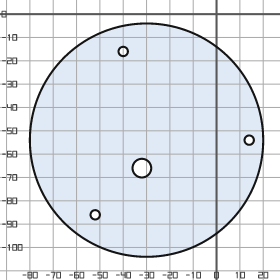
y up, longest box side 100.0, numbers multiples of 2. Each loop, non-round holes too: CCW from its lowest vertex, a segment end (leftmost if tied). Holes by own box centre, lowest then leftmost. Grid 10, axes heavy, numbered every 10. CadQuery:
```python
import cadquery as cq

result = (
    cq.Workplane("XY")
    .moveTo(-30.0, -54.0)
    .circle(50.0)
    .moveTo(-52.0, -86.0)
    .circle(2.0)
    .moveTo(-32.0, -66.0)
    .circle(4.0)
    .moveTo(14.0, -54.0)
    .circle(2.0)
    .moveTo(-40.0, -16.0)
    .circle(2.0)
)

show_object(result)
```